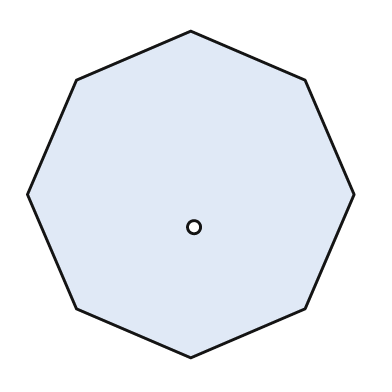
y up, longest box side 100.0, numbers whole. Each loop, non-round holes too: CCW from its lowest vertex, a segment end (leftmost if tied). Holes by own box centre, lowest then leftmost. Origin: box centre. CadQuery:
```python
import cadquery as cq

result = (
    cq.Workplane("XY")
    .moveTo(0.0, -50.0)
    .lineTo(35.0, -35.0)
    .lineTo(50.0, 0.0)
    .lineTo(35.0, 35.0)
    .lineTo(0.0, 50.0)
    .lineTo(-35.0, 35.0)
    .lineTo(-50.0, 0.0)
    .lineTo(-35.0, -35.0)
    .close()
    .moveTo(1.0, -10.0)
    .circle(2.0)
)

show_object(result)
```